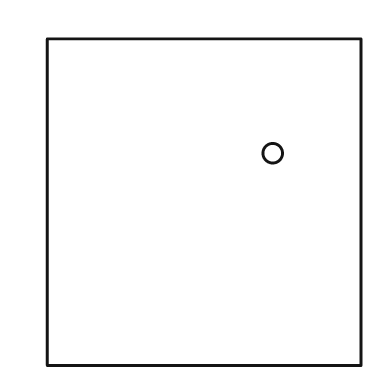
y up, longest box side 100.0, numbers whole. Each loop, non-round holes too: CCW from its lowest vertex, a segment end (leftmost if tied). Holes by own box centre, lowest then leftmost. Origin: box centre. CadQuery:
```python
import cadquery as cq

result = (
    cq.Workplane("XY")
    .moveTo(-48.0, -50.0)
    .lineTo(48.0, -50.0)
    .lineTo(48.0, 50.0)
    .lineTo(-48.0, 50.0)
    .close()
    .moveTo(21.0, 15.0)
    .circle(3.0)
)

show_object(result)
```